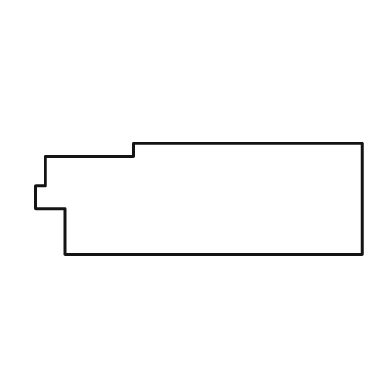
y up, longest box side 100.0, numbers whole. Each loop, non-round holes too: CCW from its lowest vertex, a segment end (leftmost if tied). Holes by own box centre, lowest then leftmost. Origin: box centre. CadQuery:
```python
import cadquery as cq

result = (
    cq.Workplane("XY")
    .moveTo(-41.0, -17.0)
    .lineTo(50.0, -17.0)
    .lineTo(50.0, 17.0)
    .lineTo(-20.0, 17.0)
    .lineTo(-20.0, 13.0)
    .lineTo(-47.0, 13.0)
    .lineTo(-47.0, 4.0)
    .lineTo(-50.0, 4.0)
    .lineTo(-50.0, -3.0)
    .lineTo(-41.0, -3.0)
    .close()
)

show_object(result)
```